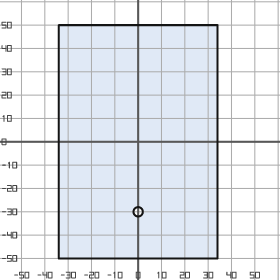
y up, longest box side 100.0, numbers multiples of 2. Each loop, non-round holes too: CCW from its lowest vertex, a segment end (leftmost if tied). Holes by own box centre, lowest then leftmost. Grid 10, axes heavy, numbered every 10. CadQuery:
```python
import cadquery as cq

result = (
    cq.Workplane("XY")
    .moveTo(-34.0, -50.0)
    .lineTo(34.0, -50.0)
    .lineTo(34.0, 50.0)
    .lineTo(-34.0, 50.0)
    .close()
    .moveTo(0.0, -30.0)
    .circle(2.0)
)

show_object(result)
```